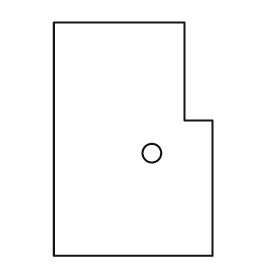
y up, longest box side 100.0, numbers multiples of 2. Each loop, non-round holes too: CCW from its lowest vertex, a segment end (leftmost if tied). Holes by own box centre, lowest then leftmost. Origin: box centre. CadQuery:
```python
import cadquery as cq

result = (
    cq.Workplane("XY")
    .moveTo(-34.0, -50.0)
    .lineTo(34.0, -50.0)
    .lineTo(34.0, 8.0)
    .lineTo(22.0, 8.0)
    .lineTo(22.0, 50.0)
    .lineTo(-34.0, 50.0)
    .close()
    .moveTo(8.0, -6.0)
    .circle(4.0)
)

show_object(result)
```